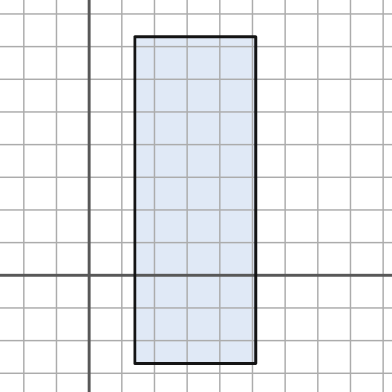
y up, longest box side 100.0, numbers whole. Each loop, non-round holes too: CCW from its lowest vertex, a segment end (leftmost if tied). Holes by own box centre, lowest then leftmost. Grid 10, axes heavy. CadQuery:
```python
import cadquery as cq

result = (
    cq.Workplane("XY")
    .moveTo(14.0, -27.0)
    .lineTo(51.0, -27.0)
    .lineTo(51.0, 73.0)
    .lineTo(14.0, 73.0)
    .close()
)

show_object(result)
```